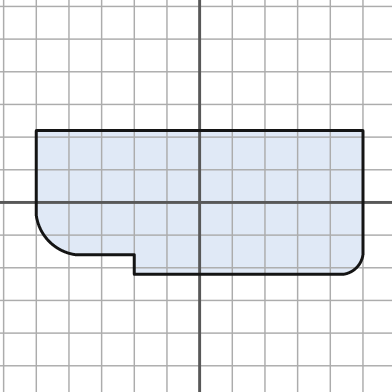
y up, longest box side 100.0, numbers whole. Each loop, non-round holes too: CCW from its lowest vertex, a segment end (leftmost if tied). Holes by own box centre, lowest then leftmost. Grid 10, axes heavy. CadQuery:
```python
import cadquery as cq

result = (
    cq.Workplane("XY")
    .moveTo(-20.0, -22.0)
    .lineTo(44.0, -22.0)
    .threePointArc((48.0, -20.0), (50.0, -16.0))
    .lineTo(50.0, 22.0)
    .lineTo(-50.0, 22.0)
    .lineTo(-50.0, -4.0)
    .threePointArc((-46.0, -12.0), (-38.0, -16.0))
    .lineTo(-20.0, -16.0)
    .close()
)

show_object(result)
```